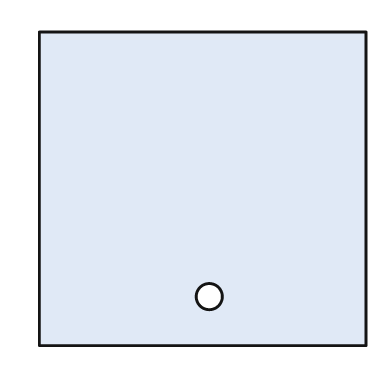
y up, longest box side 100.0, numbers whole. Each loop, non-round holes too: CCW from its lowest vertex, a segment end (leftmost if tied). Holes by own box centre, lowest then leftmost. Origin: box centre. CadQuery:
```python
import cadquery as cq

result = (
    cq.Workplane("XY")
    .moveTo(-50.0, -48.0)
    .lineTo(50.0, -48.0)
    .lineTo(50.0, 48.0)
    .lineTo(-50.0, 48.0)
    .close()
    .moveTo(2.0, -33.0)
    .circle(4.0)
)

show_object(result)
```